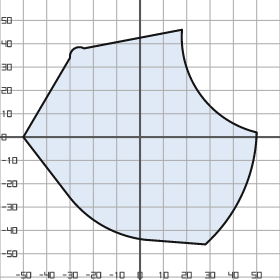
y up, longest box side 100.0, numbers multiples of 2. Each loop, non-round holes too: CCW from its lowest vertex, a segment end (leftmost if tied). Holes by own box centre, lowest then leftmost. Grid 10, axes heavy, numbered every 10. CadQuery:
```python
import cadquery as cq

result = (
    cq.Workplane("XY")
    .moveTo(28.0, -46.0)
    .threePointArc((44.0, -24.0), (50.0, 2.0))
    .threePointArc((26.0, 18.0), (18.0, 46.0))
    .lineTo(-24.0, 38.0)
    .threePointArc((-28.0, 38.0), (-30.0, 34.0))
    .lineTo(-50.0, 0.0)
    .lineTo(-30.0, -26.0)
    .threePointArc((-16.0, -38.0), (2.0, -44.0))
    .close()
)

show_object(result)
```